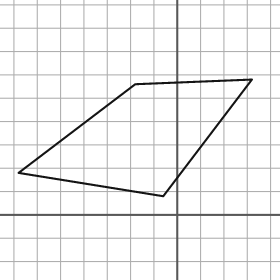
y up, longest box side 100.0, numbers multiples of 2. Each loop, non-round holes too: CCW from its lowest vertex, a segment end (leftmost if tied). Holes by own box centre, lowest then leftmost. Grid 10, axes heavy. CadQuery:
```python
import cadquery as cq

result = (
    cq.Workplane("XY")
    .moveTo(-6.0, 8.0)
    .lineTo(32.0, 58.0)
    .lineTo(-18.0, 56.0)
    .lineTo(-68.0, 18.0)
    .close()
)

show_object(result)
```